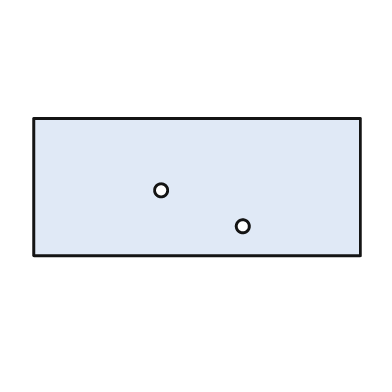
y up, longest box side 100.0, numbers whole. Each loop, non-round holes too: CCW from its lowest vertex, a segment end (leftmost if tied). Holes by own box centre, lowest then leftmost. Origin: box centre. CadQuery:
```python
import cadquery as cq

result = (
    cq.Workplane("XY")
    .moveTo(-50.0, -21.0)
    .lineTo(50.0, -21.0)
    .lineTo(50.0, 21.0)
    .lineTo(-50.0, 21.0)
    .close()
    .moveTo(14.0, -12.0)
    .circle(2.0)
    .moveTo(-11.0, -1.0)
    .circle(2.0)
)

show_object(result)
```